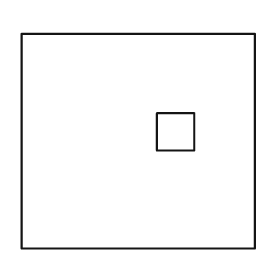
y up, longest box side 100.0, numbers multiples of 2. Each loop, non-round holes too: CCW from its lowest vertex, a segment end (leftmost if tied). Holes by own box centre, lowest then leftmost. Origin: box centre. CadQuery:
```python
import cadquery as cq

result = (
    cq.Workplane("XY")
    .moveTo(-50.0, -46.0)
    .lineTo(50.0, -46.0)
    .lineTo(50.0, 46.0)
    .lineTo(-50.0, 46.0)
    .close()
    .moveTo(8.0, -4.0)
    .lineTo(24.0, -4.0)
    .lineTo(24.0, 12.0)
    .lineTo(8.0, 12.0)
    .close()
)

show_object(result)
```